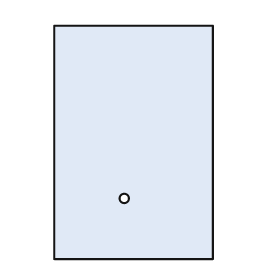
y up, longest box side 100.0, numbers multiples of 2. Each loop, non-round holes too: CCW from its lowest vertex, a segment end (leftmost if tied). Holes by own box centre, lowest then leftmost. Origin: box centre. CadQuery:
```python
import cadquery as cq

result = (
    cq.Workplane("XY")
    .moveTo(-34.0, -50.0)
    .lineTo(34.0, -50.0)
    .lineTo(34.0, 50.0)
    .lineTo(-34.0, 50.0)
    .close()
    .moveTo(-4.0, -24.0)
    .circle(2.0)
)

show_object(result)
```